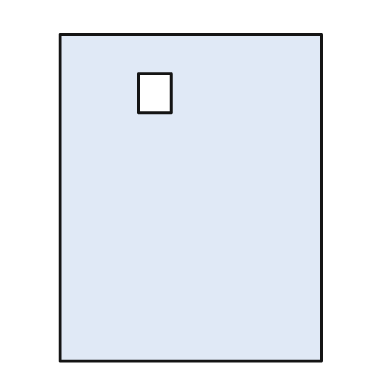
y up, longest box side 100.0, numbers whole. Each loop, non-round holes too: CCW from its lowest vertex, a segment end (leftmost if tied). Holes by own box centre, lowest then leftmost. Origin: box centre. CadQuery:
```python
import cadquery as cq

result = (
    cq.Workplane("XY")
    .moveTo(-40.0, -50.0)
    .lineTo(40.0, -50.0)
    .lineTo(40.0, 50.0)
    .lineTo(-40.0, 50.0)
    .close()
    .moveTo(-16.0, 26.0)
    .lineTo(-6.0, 26.0)
    .lineTo(-6.0, 38.0)
    .lineTo(-16.0, 38.0)
    .close()
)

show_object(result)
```